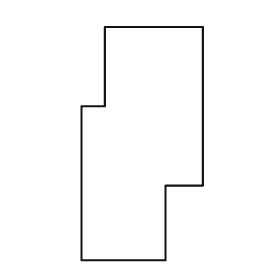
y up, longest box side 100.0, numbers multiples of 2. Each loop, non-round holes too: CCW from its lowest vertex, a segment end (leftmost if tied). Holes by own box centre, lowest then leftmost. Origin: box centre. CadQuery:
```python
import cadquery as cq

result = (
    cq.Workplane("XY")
    .moveTo(-26.0, -50.0)
    .lineTo(10.0, -50.0)
    .lineTo(10.0, -18.0)
    .lineTo(26.0, -18.0)
    .lineTo(26.0, 50.0)
    .lineTo(-16.0, 50.0)
    .lineTo(-16.0, 16.0)
    .lineTo(-26.0, 16.0)
    .close()
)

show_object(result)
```